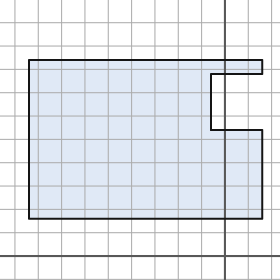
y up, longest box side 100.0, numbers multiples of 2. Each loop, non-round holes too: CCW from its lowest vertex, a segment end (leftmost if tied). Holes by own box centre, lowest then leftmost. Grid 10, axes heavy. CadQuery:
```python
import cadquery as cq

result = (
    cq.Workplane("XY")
    .moveTo(-84.0, 16.0)
    .lineTo(16.0, 16.0)
    .lineTo(16.0, 54.0)
    .lineTo(-6.0, 54.0)
    .lineTo(-6.0, 78.0)
    .lineTo(16.0, 78.0)
    .lineTo(16.0, 84.0)
    .lineTo(-84.0, 84.0)
    .close()
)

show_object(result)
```